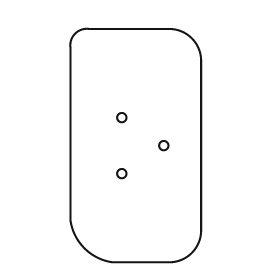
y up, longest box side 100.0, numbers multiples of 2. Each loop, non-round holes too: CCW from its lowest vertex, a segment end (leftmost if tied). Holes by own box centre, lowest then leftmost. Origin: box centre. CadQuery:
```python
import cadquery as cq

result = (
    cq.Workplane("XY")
    .moveTo(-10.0, -50.0)
    .lineTo(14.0, -50.0)
    .threePointArc((24.0, -46.0), (28.0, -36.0))
    .lineTo(28.0, 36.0)
    .threePointArc((24.0, 46.0), (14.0, 50.0))
    .lineTo(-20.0, 50.0)
    .threePointArc((-26.0, 48.0), (-28.0, 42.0))
    .lineTo(-28.0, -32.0)
    .threePointArc((-22.0, -44.0), (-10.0, -50.0))
    .close()
    .moveTo(-6.0, -12.0)
    .circle(2.0)
    .moveTo(12.0, 0.0)
    .circle(2.0)
    .moveTo(-6.0, 12.0)
    .circle(2.0)
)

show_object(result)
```